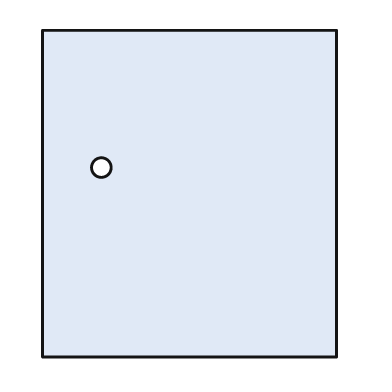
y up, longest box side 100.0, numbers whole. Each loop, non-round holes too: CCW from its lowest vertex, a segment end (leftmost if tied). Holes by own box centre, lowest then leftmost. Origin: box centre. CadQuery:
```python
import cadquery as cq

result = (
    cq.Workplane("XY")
    .moveTo(-45.0, -50.0)
    .lineTo(45.0, -50.0)
    .lineTo(45.0, 50.0)
    .lineTo(-45.0, 50.0)
    .close()
    .moveTo(-27.0, 8.0)
    .circle(3.0)
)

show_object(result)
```